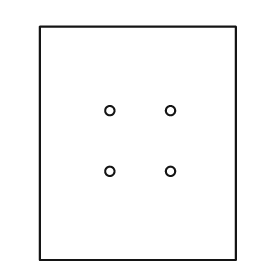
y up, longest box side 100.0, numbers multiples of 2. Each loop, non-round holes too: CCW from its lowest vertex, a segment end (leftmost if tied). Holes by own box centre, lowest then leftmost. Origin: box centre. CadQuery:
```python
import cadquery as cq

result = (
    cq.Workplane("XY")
    .moveTo(-42.0, -50.0)
    .lineTo(42.0, -50.0)
    .lineTo(42.0, 50.0)
    .lineTo(-42.0, 50.0)
    .close()
    .moveTo(-12.0, -12.0)
    .circle(2.0)
    .moveTo(14.0, -12.0)
    .circle(2.0)
    .moveTo(-12.0, 14.0)
    .circle(2.0)
    .moveTo(14.0, 14.0)
    .circle(2.0)
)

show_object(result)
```